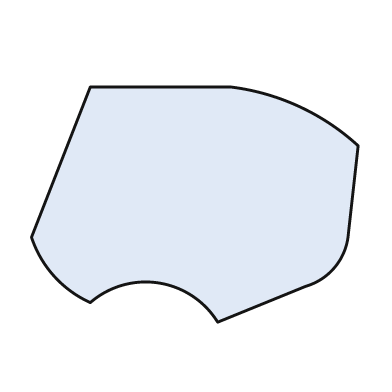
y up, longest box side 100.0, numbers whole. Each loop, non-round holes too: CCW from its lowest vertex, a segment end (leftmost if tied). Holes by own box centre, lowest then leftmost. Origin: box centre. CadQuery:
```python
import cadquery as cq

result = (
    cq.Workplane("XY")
    .moveTo(7.0, -36.0)
    .lineTo(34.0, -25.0)
    .threePointArc((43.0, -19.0), (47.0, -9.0))
    .lineTo(50.0, 18.0)
    .threePointArc((32.0, 30.0), (11.0, 36.0))
    .lineTo(-32.0, 36.0)
    .lineTo(-50.0, -10.0)
    .threePointArc((-43.0, -22.0), (-32.0, -30.0))
    .threePointArc((-11.0, -24.0), (7.0, -36.0))
    .close()
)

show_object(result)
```